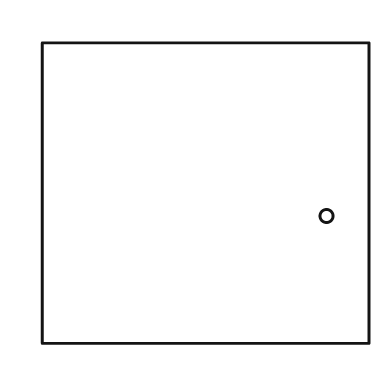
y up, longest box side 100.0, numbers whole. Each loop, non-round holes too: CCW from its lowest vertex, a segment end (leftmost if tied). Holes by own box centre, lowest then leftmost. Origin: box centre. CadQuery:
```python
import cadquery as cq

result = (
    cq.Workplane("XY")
    .moveTo(-50.0, -46.0)
    .lineTo(50.0, -46.0)
    .lineTo(50.0, 46.0)
    .lineTo(-50.0, 46.0)
    .close()
    .moveTo(37.0, -7.0)
    .circle(2.0)
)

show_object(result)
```